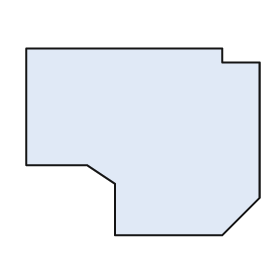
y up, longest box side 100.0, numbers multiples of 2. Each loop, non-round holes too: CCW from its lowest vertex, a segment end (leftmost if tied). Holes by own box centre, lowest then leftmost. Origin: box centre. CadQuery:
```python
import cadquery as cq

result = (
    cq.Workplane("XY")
    .moveTo(-12.0, -40.0)
    .lineTo(34.0, -40.0)
    .lineTo(50.0, -24.0)
    .lineTo(50.0, 34.0)
    .lineTo(34.0, 34.0)
    .lineTo(34.0, 40.0)
    .lineTo(-50.0, 40.0)
    .lineTo(-50.0, -10.0)
    .lineTo(-24.0, -10.0)
    .lineTo(-12.0, -18.0)
    .close()
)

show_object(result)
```